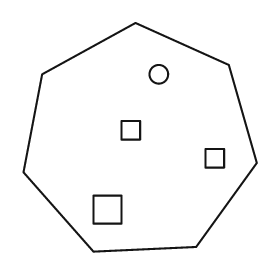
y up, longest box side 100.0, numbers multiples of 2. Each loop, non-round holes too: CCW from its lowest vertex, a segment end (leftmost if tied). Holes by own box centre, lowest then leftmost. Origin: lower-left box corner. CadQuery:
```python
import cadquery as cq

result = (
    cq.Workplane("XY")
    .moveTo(30.0, 0.0)
    .lineTo(74.0, 2.0)
    .lineTo(100.0, 38.0)
    .lineTo(88.0, 80.0)
    .lineTo(48.0, 98.0)
    .lineTo(8.0, 76.0)
    .lineTo(0.0, 34.0)
    .close()
    .moveTo(30.0, 12.0)
    .lineTo(42.0, 12.0)
    .lineTo(42.0, 24.0)
    .lineTo(30.0, 24.0)
    .close()
    .moveTo(78.0, 36.0)
    .lineTo(86.0, 36.0)
    .lineTo(86.0, 44.0)
    .lineTo(78.0, 44.0)
    .close()
    .moveTo(42.0, 48.0)
    .lineTo(50.0, 48.0)
    .lineTo(50.0, 56.0)
    .lineTo(42.0, 56.0)
    .close()
    .moveTo(58.0, 76.0)
    .circle(4.0)
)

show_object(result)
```